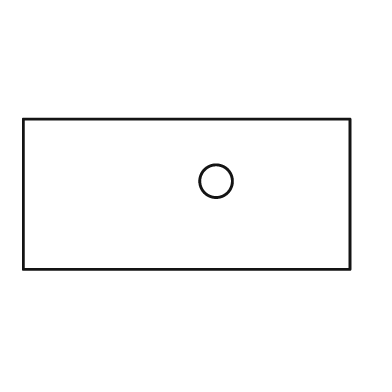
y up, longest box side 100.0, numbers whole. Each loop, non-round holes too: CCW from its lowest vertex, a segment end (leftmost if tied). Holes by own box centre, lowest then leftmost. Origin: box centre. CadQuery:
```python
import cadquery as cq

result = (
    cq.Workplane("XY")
    .moveTo(-50.0, -23.0)
    .lineTo(50.0, -23.0)
    .lineTo(50.0, 23.0)
    .lineTo(-50.0, 23.0)
    .close()
    .moveTo(9.0, 4.0)
    .circle(5.0)
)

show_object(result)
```